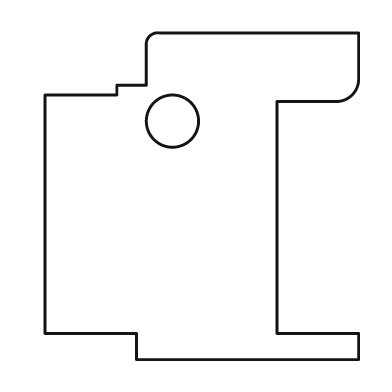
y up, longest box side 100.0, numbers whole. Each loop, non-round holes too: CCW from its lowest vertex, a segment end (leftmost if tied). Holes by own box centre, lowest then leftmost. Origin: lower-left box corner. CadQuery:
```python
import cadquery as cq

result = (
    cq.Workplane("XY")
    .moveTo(28.0, 0.0)
    .lineTo(96.0, 0.0)
    .lineTo(96.0, 8.0)
    .lineTo(71.0, 8.0)
    .lineTo(71.0, 79.0)
    .lineTo(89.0, 79.0)
    .threePointArc((94.0, 81.0), (96.0, 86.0))
    .lineTo(96.0, 100.0)
    .lineTo(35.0, 100.0)
    .threePointArc((32.0, 99.0), (31.0, 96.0))
    .lineTo(31.0, 84.0)
    .lineTo(22.0, 84.0)
    .lineTo(22.0, 81.0)
    .lineTo(0.0, 81.0)
    .lineTo(0.0, 8.0)
    .lineTo(28.0, 8.0)
    .close()
    .moveTo(39.0, 73.0)
    .circle(8.0)
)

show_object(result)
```